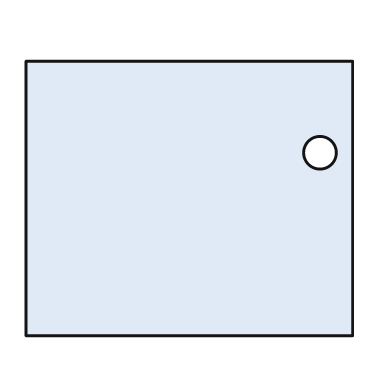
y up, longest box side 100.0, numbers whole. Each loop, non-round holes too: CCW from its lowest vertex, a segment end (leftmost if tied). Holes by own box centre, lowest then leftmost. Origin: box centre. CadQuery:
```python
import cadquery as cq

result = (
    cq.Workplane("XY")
    .moveTo(-50.0, -42.0)
    .lineTo(50.0, -42.0)
    .lineTo(50.0, 42.0)
    .lineTo(-50.0, 42.0)
    .close()
    .moveTo(40.0, 14.0)
    .circle(5.0)
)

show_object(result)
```